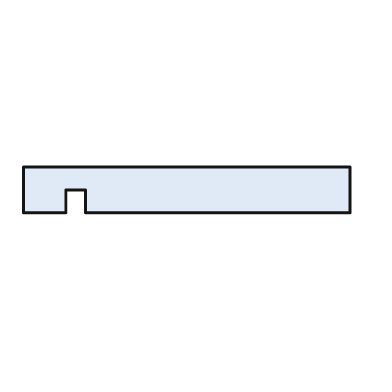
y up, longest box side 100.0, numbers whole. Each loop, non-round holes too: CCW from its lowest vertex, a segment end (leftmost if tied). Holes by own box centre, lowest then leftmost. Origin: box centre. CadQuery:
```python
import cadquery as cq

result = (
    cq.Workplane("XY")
    .moveTo(-50.0, -7.0)
    .lineTo(-37.0, -7.0)
    .lineTo(-37.0, 0.0)
    .lineTo(-31.0, 0.0)
    .lineTo(-31.0, -7.0)
    .lineTo(50.0, -7.0)
    .lineTo(50.0, 7.0)
    .lineTo(-50.0, 7.0)
    .close()
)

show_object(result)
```